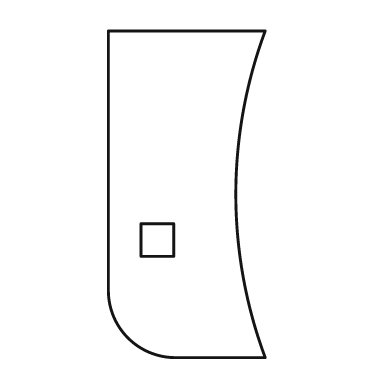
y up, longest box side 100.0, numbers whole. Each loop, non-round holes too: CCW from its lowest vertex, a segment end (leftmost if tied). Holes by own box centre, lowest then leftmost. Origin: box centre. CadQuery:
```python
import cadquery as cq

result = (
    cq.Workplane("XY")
    .moveTo(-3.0, -50.0)
    .lineTo(24.0, -50.0)
    .threePointArc((15.0, 0.0), (24.0, 50.0))
    .lineTo(-24.0, 50.0)
    .lineTo(-24.0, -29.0)
    .threePointArc((-18.0, -44.0), (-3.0, -50.0))
    .close()
    .moveTo(-14.0, -19.0)
    .lineTo(-4.0, -19.0)
    .lineTo(-4.0, -9.0)
    .lineTo(-14.0, -9.0)
    .close()
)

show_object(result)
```